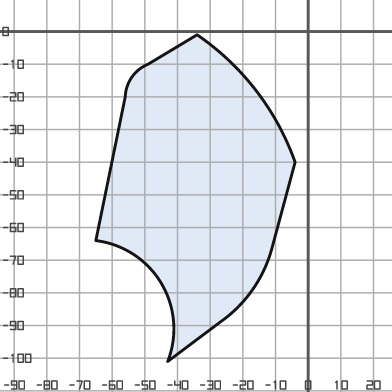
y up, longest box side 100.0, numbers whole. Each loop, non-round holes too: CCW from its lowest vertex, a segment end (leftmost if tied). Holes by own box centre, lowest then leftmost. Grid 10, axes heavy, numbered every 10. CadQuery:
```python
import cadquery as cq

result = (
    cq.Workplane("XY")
    .moveTo(-43.0, -101.0)
    .lineTo(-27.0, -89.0)
    .threePointArc((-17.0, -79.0), (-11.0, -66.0))
    .lineTo(-4.0, -40.0)
    .threePointArc((-16.0, -18.0), (-34.0, -1.0))
    .lineTo(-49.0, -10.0)
    .threePointArc((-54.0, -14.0), (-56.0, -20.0))
    .lineTo(-65.0, -64.0)
    .threePointArc((-45.0, -77.0), (-43.0, -101.0))
    .close()
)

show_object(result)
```